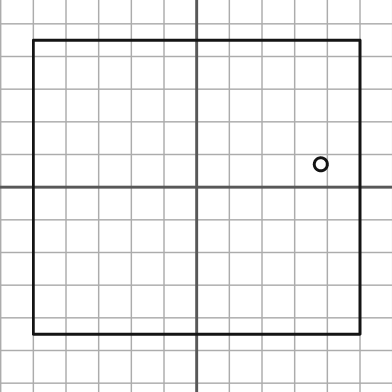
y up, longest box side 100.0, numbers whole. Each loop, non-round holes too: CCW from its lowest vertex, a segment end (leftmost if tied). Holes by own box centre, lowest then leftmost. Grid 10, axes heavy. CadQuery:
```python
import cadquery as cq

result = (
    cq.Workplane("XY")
    .moveTo(-50.0, -45.0)
    .lineTo(50.0, -45.0)
    .lineTo(50.0, 45.0)
    .lineTo(-50.0, 45.0)
    .close()
    .moveTo(38.0, 7.0)
    .circle(2.0)
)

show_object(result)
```